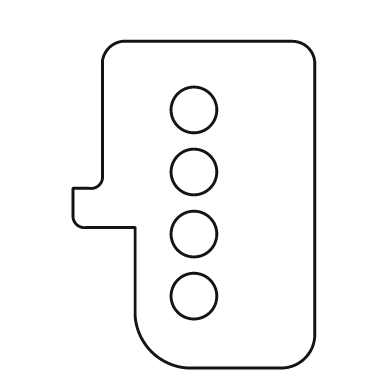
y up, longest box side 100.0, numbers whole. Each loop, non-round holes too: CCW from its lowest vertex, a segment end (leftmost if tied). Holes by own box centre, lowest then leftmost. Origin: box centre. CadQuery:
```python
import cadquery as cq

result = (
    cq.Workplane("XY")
    .moveTo(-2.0, -50.0)
    .lineTo(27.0, -50.0)
    .threePointArc((34.0, -47.0), (37.0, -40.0))
    .lineTo(37.0, 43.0)
    .threePointArc((35.0, 48.0), (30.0, 50.0))
    .lineTo(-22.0, 50.0)
    .threePointArc((-26.0, 48.0), (-28.0, 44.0))
    .lineTo(-28.0, 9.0)
    .threePointArc((-29.0, 6.0), (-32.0, 5.0))
    .lineTo(-37.0, 5.0)
    .lineTo(-37.0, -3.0)
    .threePointArc((-36.0, -6.0), (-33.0, -7.0))
    .lineTo(-18.0, -7.0)
    .lineTo(-18.0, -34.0)
    .threePointArc((-13.0, -45.0), (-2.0, -50.0))
    .close()
    .moveTo(0.0, -28.0)
    .circle(7.0)
    .moveTo(0.0, -9.0)
    .circle(7.0)
    .moveTo(0.0, 10.0)
    .circle(7.0)
    .moveTo(0.0, 29.0)
    .circle(7.0)
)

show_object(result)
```